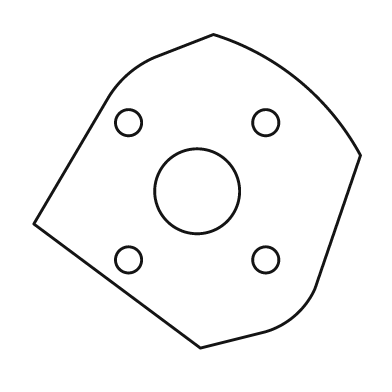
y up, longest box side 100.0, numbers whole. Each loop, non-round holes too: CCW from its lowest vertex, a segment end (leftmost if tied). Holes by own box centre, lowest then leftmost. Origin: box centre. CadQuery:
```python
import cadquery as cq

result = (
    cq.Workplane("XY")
    .moveTo(1.0, -48.0)
    .lineTo(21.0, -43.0)
    .threePointArc((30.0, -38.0), (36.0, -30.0))
    .lineTo(50.0, 11.0)
    .threePointArc((31.0, 34.0), (5.0, 48.0))
    .lineTo(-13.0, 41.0)
    .threePointArc((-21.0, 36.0), (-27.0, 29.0))
    .lineTo(-50.0, -10.0)
    .close()
    .moveTo(-21.0, -21.0)
    .circle(4.0)
    .moveTo(21.0, -21.0)
    .circle(4.0)
    .moveTo(0.0, 0.0)
    .circle(13.0)
    .moveTo(-21.0, 21.0)
    .circle(4.0)
    .moveTo(21.0, 21.0)
    .circle(4.0)
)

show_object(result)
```